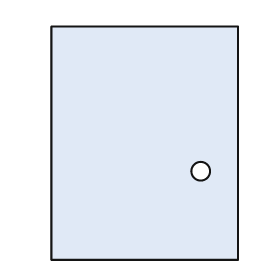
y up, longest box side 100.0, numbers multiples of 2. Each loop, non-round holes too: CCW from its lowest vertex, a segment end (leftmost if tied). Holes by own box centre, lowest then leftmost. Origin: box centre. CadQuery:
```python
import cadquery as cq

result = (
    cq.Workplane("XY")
    .moveTo(-40.0, -50.0)
    .lineTo(40.0, -50.0)
    .lineTo(40.0, 50.0)
    .lineTo(-40.0, 50.0)
    .close()
    .moveTo(24.0, -12.0)
    .circle(4.0)
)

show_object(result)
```